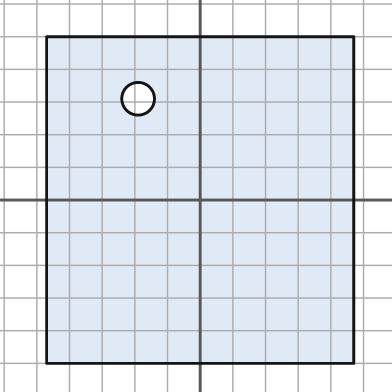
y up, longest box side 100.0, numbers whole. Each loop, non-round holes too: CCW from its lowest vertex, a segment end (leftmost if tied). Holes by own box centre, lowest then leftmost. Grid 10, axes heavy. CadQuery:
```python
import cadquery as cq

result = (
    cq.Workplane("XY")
    .moveTo(-47.0, -50.0)
    .lineTo(47.0, -50.0)
    .lineTo(47.0, 50.0)
    .lineTo(-47.0, 50.0)
    .close()
    .moveTo(-19.0, 31.0)
    .circle(5.0)
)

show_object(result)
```